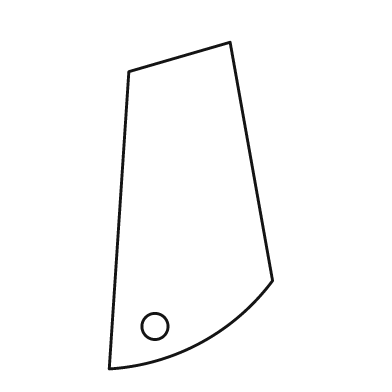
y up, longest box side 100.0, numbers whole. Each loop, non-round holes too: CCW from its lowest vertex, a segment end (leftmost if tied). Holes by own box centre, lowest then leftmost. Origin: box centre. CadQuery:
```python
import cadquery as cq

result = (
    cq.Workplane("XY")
    .moveTo(-25.0, -50.0)
    .threePointArc((3.0, -42.0), (25.0, -23.0))
    .lineTo(12.0, 50.0)
    .lineTo(-19.0, 41.0)
    .close()
    .moveTo(-11.0, -37.0)
    .circle(4.0)
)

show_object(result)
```